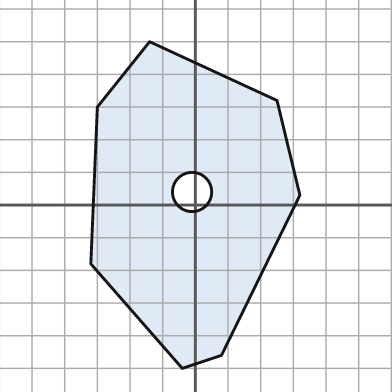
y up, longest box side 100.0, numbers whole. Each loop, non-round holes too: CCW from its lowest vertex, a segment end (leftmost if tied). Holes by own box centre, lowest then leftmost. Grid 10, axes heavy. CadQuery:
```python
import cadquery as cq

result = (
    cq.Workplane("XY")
    .moveTo(-4.0, -50.0)
    .lineTo(8.0, -46.0)
    .lineTo(32.0, 3.0)
    .lineTo(25.0, 32.0)
    .lineTo(-14.0, 50.0)
    .lineTo(-30.0, 30.0)
    .lineTo(-32.0, -18.0)
    .close()
    .moveTo(-1.0, 4.0)
    .circle(6.0)
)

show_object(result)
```